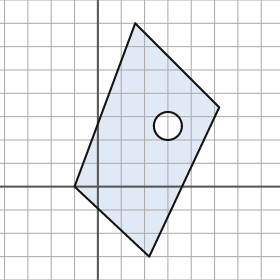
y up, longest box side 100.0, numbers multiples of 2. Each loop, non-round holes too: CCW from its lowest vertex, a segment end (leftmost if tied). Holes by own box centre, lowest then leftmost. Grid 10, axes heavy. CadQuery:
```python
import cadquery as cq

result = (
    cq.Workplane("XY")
    .moveTo(22.0, -30.0)
    .lineTo(52.0, 34.0)
    .lineTo(16.0, 70.0)
    .lineTo(-10.0, 0.0)
    .close()
    .moveTo(30.0, 26.0)
    .circle(6.0)
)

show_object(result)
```